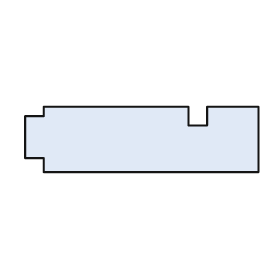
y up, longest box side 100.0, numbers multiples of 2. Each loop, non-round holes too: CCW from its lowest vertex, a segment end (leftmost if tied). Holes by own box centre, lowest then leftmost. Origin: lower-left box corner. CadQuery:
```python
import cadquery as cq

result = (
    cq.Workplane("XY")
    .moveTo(8.0, 0.0)
    .lineTo(100.0, 0.0)
    .lineTo(100.0, 28.0)
    .lineTo(78.0, 28.0)
    .lineTo(78.0, 20.0)
    .lineTo(70.0, 20.0)
    .lineTo(70.0, 28.0)
    .lineTo(8.0, 28.0)
    .lineTo(8.0, 24.0)
    .lineTo(0.0, 24.0)
    .lineTo(0.0, 6.0)
    .lineTo(8.0, 6.0)
    .close()
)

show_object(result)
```